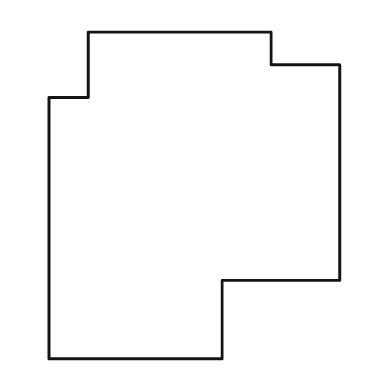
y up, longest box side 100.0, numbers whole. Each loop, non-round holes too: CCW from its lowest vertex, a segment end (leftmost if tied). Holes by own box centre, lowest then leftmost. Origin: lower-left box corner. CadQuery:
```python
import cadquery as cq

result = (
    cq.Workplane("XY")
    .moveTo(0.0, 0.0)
    .lineTo(53.0, 0.0)
    .lineTo(53.0, 24.0)
    .lineTo(89.0, 24.0)
    .lineTo(89.0, 90.0)
    .lineTo(68.0, 90.0)
    .lineTo(68.0, 100.0)
    .lineTo(12.0, 100.0)
    .lineTo(12.0, 80.0)
    .lineTo(0.0, 80.0)
    .close()
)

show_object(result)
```